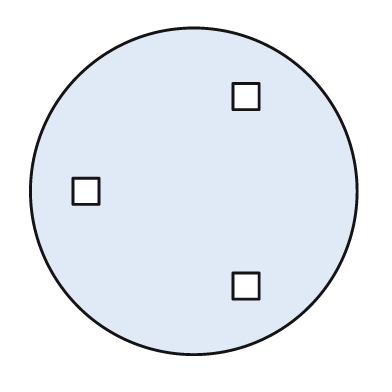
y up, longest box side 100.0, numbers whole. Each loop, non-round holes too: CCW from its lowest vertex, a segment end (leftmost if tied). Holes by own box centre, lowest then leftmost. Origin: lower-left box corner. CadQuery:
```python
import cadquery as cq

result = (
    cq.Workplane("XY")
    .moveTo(50.0, 50.0)
    .circle(50.0)
    .moveTo(62.0, 17.0)
    .lineTo(70.0, 17.0)
    .lineTo(70.0, 25.0)
    .lineTo(62.0, 25.0)
    .close()
    .moveTo(13.0, 46.0)
    .lineTo(21.0, 46.0)
    .lineTo(21.0, 54.0)
    .lineTo(13.0, 54.0)
    .close()
    .moveTo(62.0, 75.0)
    .lineTo(70.0, 75.0)
    .lineTo(70.0, 83.0)
    .lineTo(62.0, 83.0)
    .close()
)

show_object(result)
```